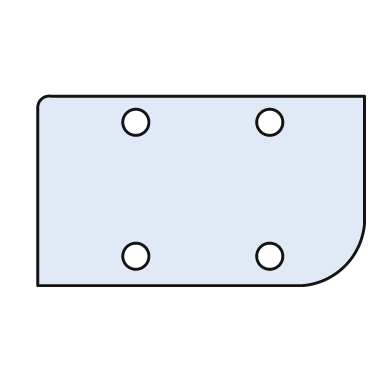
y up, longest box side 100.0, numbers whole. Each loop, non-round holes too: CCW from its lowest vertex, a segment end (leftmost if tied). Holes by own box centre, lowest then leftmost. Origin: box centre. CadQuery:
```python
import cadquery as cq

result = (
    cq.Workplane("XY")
    .moveTo(-50.0, -29.0)
    .lineTo(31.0, -29.0)
    .threePointArc((44.0, -23.0), (50.0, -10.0))
    .lineTo(50.0, 29.0)
    .lineTo(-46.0, 29.0)
    .threePointArc((-49.0, 28.0), (-50.0, 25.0))
    .close()
    .moveTo(-20.0, -20.0)
    .circle(4.0)
    .moveTo(21.0, -20.0)
    .circle(4.0)
    .moveTo(-20.0, 21.0)
    .circle(4.0)
    .moveTo(21.0, 21.0)
    .circle(4.0)
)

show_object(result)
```